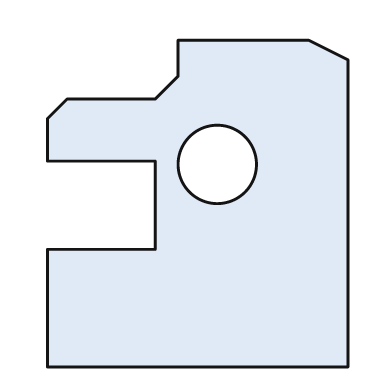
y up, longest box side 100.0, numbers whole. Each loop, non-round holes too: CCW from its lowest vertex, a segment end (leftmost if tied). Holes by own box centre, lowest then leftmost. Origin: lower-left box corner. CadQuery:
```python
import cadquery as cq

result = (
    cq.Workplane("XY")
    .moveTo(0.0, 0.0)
    .lineTo(92.0, 0.0)
    .lineTo(92.0, 94.0)
    .lineTo(80.0, 100.0)
    .lineTo(40.0, 100.0)
    .lineTo(40.0, 89.0)
    .lineTo(33.0, 82.0)
    .lineTo(6.0, 82.0)
    .lineTo(0.0, 76.0)
    .lineTo(0.0, 63.0)
    .lineTo(33.0, 63.0)
    .lineTo(33.0, 36.0)
    .lineTo(0.0, 36.0)
    .close()
    .moveTo(52.0, 62.0)
    .circle(12.0)
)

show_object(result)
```